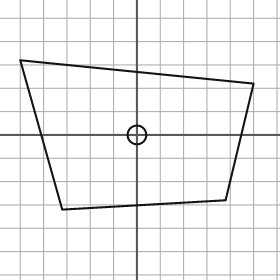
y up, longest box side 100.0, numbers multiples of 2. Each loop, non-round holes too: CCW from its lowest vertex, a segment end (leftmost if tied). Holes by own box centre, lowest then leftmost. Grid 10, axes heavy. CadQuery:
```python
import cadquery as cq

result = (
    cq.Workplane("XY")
    .moveTo(-32.0, -32.0)
    .lineTo(38.0, -28.0)
    .lineTo(50.0, 22.0)
    .lineTo(-50.0, 32.0)
    .close()
    .moveTo(0.0, 0.0)
    .circle(4.0)
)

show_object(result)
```